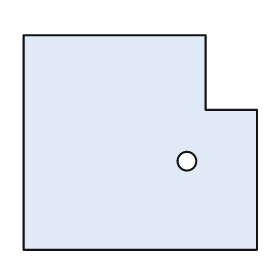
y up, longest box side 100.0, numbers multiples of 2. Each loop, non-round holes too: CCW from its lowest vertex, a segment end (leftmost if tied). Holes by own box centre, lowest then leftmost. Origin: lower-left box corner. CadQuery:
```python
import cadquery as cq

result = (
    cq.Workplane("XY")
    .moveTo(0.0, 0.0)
    .lineTo(100.0, 0.0)
    .lineTo(100.0, 60.0)
    .lineTo(78.0, 60.0)
    .lineTo(78.0, 92.0)
    .lineTo(0.0, 92.0)
    .close()
    .moveTo(70.0, 38.0)
    .circle(4.0)
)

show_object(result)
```